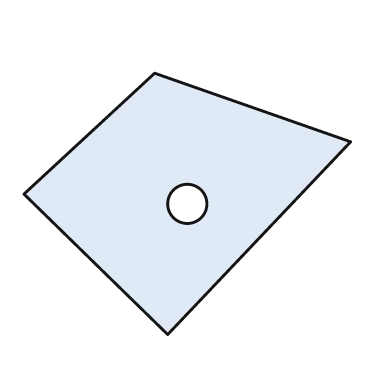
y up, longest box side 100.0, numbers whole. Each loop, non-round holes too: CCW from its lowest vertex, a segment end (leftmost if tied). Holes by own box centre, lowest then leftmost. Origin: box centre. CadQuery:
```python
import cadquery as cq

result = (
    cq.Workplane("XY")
    .moveTo(-6.0, -40.0)
    .lineTo(50.0, 19.0)
    .lineTo(-10.0, 40.0)
    .lineTo(-50.0, 3.0)
    .close()
    .moveTo(0.0, 0.0)
    .circle(6.0)
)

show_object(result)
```